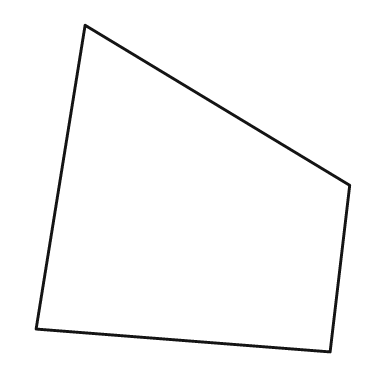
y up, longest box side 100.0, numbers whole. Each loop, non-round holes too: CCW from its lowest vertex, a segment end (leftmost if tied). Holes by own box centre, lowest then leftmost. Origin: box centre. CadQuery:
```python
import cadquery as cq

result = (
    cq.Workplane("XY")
    .moveTo(42.0, -50.0)
    .lineTo(48.0, 1.0)
    .lineTo(-33.0, 50.0)
    .lineTo(-48.0, -43.0)
    .close()
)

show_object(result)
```